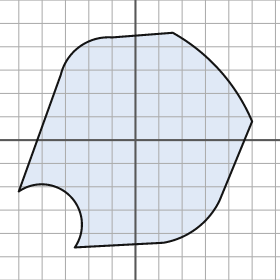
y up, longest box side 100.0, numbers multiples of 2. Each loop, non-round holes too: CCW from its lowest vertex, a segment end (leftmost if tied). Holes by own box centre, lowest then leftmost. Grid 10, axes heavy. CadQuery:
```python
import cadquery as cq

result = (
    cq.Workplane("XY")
    .moveTo(-26.0, -46.0)
    .lineTo(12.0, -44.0)
    .threePointArc((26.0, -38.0), (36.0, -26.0))
    .lineTo(50.0, 8.0)
    .threePointArc((36.0, 30.0), (16.0, 46.0))
    .lineTo(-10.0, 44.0)
    .threePointArc((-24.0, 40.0), (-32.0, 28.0))
    .lineTo(-50.0, -22.0)
    .threePointArc((-28.0, -24.0), (-26.0, -46.0))
    .close()
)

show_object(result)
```